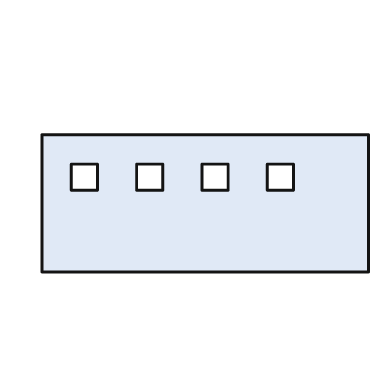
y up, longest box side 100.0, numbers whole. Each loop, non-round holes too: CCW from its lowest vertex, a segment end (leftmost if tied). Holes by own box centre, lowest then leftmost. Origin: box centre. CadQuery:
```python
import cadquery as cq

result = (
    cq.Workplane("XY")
    .moveTo(-50.0, -21.0)
    .lineTo(50.0, -21.0)
    .lineTo(50.0, 21.0)
    .lineTo(-50.0, 21.0)
    .close()
    .moveTo(-41.0, 4.0)
    .lineTo(-33.0, 4.0)
    .lineTo(-33.0, 12.0)
    .lineTo(-41.0, 12.0)
    .close()
    .moveTo(-21.0, 4.0)
    .lineTo(-13.0, 4.0)
    .lineTo(-13.0, 12.0)
    .lineTo(-21.0, 12.0)
    .close()
    .moveTo(-1.0, 4.0)
    .lineTo(7.0, 4.0)
    .lineTo(7.0, 12.0)
    .lineTo(-1.0, 12.0)
    .close()
    .moveTo(19.0, 4.0)
    .lineTo(27.0, 4.0)
    .lineTo(27.0, 12.0)
    .lineTo(19.0, 12.0)
    .close()
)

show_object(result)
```